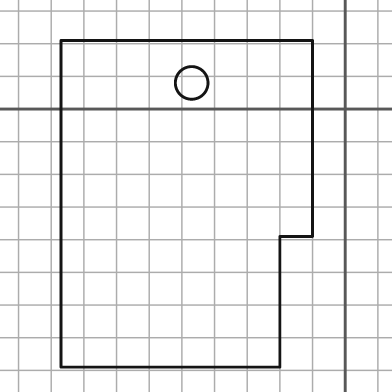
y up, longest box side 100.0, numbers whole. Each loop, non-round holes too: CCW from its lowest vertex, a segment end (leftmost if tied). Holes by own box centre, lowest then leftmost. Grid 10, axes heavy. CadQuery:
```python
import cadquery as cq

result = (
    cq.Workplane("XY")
    .moveTo(-87.0, -79.0)
    .lineTo(-20.0, -79.0)
    .lineTo(-20.0, -39.0)
    .lineTo(-10.0, -39.0)
    .lineTo(-10.0, 21.0)
    .lineTo(-87.0, 21.0)
    .close()
    .moveTo(-47.0, 8.0)
    .circle(5.0)
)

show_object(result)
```